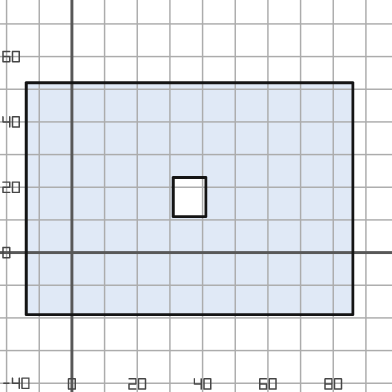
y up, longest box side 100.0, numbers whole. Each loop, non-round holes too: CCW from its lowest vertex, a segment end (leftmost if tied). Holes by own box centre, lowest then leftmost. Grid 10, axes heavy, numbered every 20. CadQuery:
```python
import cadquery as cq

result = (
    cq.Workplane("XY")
    .moveTo(-14.0, -19.0)
    .lineTo(86.0, -19.0)
    .lineTo(86.0, 52.0)
    .lineTo(-14.0, 52.0)
    .close()
    .moveTo(31.0, 11.0)
    .lineTo(41.0, 11.0)
    .lineTo(41.0, 23.0)
    .lineTo(31.0, 23.0)
    .close()
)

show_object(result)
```